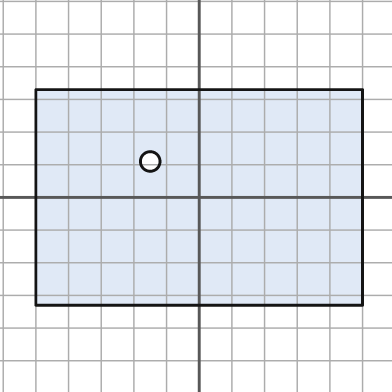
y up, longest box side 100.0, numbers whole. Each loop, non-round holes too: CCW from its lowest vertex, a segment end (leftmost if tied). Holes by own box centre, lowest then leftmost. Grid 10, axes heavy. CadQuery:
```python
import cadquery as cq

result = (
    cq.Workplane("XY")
    .moveTo(-50.0, -33.0)
    .lineTo(50.0, -33.0)
    .lineTo(50.0, 33.0)
    .lineTo(-50.0, 33.0)
    .close()
    .moveTo(-15.0, 11.0)
    .circle(3.0)
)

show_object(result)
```